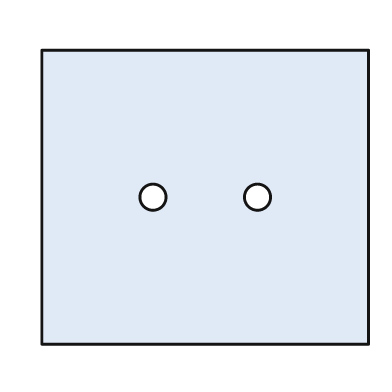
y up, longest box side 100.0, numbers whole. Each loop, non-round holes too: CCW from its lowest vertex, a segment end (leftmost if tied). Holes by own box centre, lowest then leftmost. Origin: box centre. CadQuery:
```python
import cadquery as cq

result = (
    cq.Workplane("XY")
    .moveTo(-50.0, -45.0)
    .lineTo(50.0, -45.0)
    .lineTo(50.0, 45.0)
    .lineTo(-50.0, 45.0)
    .close()
    .moveTo(-16.0, 0.0)
    .circle(4.0)
    .moveTo(16.0, 0.0)
    .circle(4.0)
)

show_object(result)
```